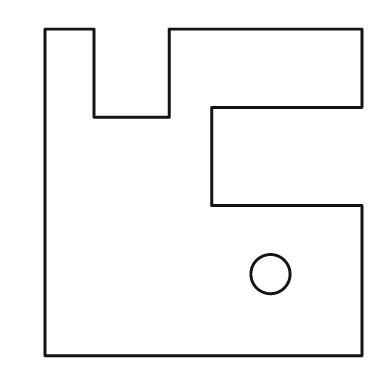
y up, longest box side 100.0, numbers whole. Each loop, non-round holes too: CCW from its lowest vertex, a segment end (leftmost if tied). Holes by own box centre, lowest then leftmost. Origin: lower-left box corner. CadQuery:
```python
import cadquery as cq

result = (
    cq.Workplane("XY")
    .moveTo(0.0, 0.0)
    .lineTo(97.0, 0.0)
    .lineTo(97.0, 46.0)
    .lineTo(51.0, 46.0)
    .lineTo(51.0, 76.0)
    .lineTo(97.0, 76.0)
    .lineTo(97.0, 100.0)
    .lineTo(38.0, 100.0)
    .lineTo(38.0, 73.0)
    .lineTo(15.0, 73.0)
    .lineTo(15.0, 100.0)
    .lineTo(0.0, 100.0)
    .close()
    .moveTo(69.0, 25.0)
    .circle(6.0)
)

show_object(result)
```